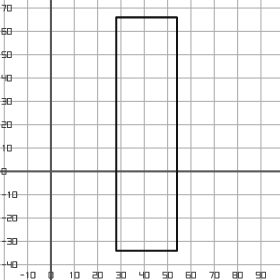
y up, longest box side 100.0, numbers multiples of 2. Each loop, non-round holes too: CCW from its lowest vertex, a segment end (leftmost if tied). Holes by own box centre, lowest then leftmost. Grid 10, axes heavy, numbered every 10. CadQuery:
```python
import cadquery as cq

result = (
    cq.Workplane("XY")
    .moveTo(28.0, -34.0)
    .lineTo(54.0, -34.0)
    .lineTo(54.0, 66.0)
    .lineTo(28.0, 66.0)
    .close()
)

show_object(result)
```